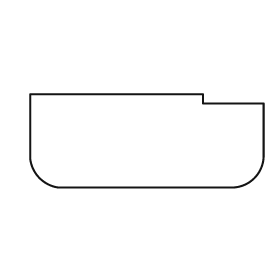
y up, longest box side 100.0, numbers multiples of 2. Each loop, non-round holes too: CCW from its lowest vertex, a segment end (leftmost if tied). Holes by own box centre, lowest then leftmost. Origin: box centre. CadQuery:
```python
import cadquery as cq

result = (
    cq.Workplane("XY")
    .moveTo(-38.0, -20.0)
    .lineTo(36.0, -20.0)
    .threePointArc((46.0, -16.0), (50.0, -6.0))
    .lineTo(50.0, 16.0)
    .lineTo(24.0, 16.0)
    .lineTo(24.0, 20.0)
    .lineTo(-50.0, 20.0)
    .lineTo(-50.0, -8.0)
    .threePointArc((-46.0, -16.0), (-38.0, -20.0))
    .close()
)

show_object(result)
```